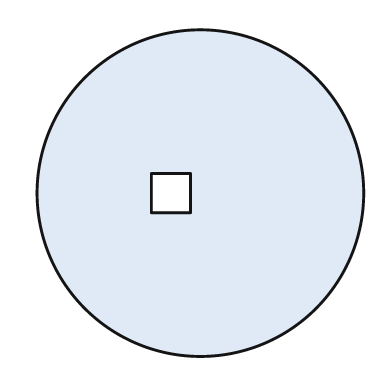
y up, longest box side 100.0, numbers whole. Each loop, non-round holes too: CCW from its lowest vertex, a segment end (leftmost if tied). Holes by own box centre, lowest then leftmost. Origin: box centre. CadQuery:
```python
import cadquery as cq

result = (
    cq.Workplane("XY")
    .moveTo(0.0, 0.0)
    .circle(50.0)
    .moveTo(-15.0, -6.0)
    .lineTo(-3.0, -6.0)
    .lineTo(-3.0, 6.0)
    .lineTo(-15.0, 6.0)
    .close()
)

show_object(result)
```